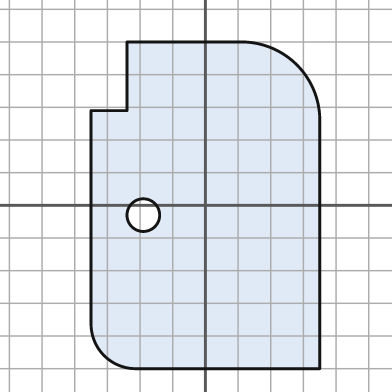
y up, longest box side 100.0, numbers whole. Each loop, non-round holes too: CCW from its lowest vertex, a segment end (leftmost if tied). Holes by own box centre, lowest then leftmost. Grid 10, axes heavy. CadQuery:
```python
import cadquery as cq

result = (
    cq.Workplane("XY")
    .moveTo(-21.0, -50.0)
    .lineTo(35.0, -50.0)
    .lineTo(35.0, 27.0)
    .threePointArc((28.0, 43.0), (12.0, 50.0))
    .lineTo(-24.0, 50.0)
    .lineTo(-24.0, 29.0)
    .lineTo(-35.0, 29.0)
    .lineTo(-35.0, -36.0)
    .threePointArc((-31.0, -46.0), (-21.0, -50.0))
    .close()
    .moveTo(-19.0, -3.0)
    .circle(5.0)
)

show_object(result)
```